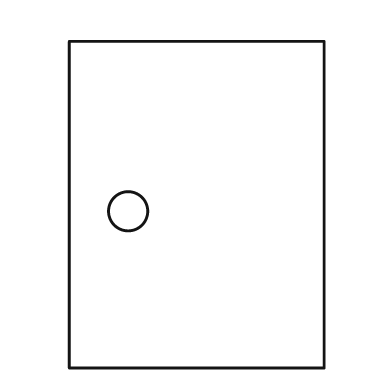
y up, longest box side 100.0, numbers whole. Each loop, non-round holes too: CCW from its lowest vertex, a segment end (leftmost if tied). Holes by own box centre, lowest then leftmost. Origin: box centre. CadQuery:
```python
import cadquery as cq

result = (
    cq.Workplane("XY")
    .moveTo(-39.0, -50.0)
    .lineTo(39.0, -50.0)
    .lineTo(39.0, 50.0)
    .lineTo(-39.0, 50.0)
    .close()
    .moveTo(-21.0, -2.0)
    .circle(6.0)
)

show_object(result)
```